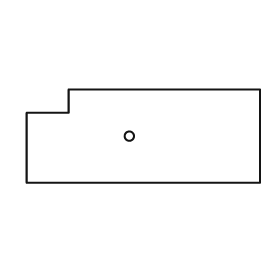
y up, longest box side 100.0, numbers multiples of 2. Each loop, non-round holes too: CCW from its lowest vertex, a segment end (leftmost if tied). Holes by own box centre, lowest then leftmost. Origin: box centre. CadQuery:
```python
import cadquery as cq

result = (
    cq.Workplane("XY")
    .moveTo(-50.0, -20.0)
    .lineTo(50.0, -20.0)
    .lineTo(50.0, 20.0)
    .lineTo(-32.0, 20.0)
    .lineTo(-32.0, 10.0)
    .lineTo(-50.0, 10.0)
    .close()
    .moveTo(-6.0, 0.0)
    .circle(2.0)
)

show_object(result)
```